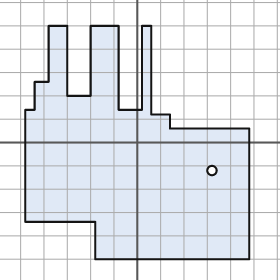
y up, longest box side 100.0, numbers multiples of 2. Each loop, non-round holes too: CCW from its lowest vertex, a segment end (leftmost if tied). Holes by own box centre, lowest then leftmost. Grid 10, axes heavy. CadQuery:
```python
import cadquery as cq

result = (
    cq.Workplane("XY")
    .moveTo(-18.0, -50.0)
    .lineTo(48.0, -50.0)
    .lineTo(48.0, 6.0)
    .lineTo(14.0, 6.0)
    .lineTo(14.0, 12.0)
    .lineTo(6.0, 12.0)
    .lineTo(6.0, 50.0)
    .lineTo(2.0, 50.0)
    .lineTo(2.0, 14.0)
    .lineTo(-8.0, 14.0)
    .lineTo(-8.0, 50.0)
    .lineTo(-20.0, 50.0)
    .lineTo(-20.0, 20.0)
    .lineTo(-30.0, 20.0)
    .lineTo(-30.0, 50.0)
    .lineTo(-38.0, 50.0)
    .lineTo(-38.0, 26.0)
    .lineTo(-44.0, 26.0)
    .lineTo(-44.0, 14.0)
    .lineTo(-48.0, 14.0)
    .lineTo(-48.0, -34.0)
    .lineTo(-18.0, -34.0)
    .close()
    .moveTo(32.0, -12.0)
    .circle(2.0)
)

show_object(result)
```